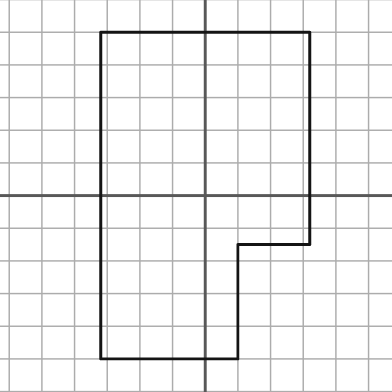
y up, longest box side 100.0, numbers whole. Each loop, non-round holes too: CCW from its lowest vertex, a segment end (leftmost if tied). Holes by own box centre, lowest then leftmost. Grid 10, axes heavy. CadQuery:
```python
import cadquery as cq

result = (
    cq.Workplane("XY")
    .moveTo(-32.0, -50.0)
    .lineTo(10.0, -50.0)
    .lineTo(10.0, -15.0)
    .lineTo(32.0, -15.0)
    .lineTo(32.0, 50.0)
    .lineTo(-32.0, 50.0)
    .close()
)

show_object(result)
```